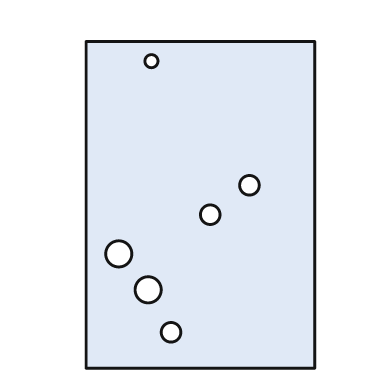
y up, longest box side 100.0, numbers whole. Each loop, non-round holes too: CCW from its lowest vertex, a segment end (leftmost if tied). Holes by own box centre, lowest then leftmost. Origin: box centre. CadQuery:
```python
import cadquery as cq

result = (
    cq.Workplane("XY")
    .moveTo(-35.0, -50.0)
    .lineTo(35.0, -50.0)
    .lineTo(35.0, 50.0)
    .lineTo(-35.0, 50.0)
    .close()
    .moveTo(-9.0, -39.0)
    .circle(3.0)
    .moveTo(-16.0, -26.0)
    .circle(4.0)
    .moveTo(-25.0, -15.0)
    .circle(4.0)
    .moveTo(3.0, -3.0)
    .circle(3.0)
    .moveTo(15.0, 6.0)
    .circle(3.0)
    .moveTo(-15.0, 44.0)
    .circle(2.0)
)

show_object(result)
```